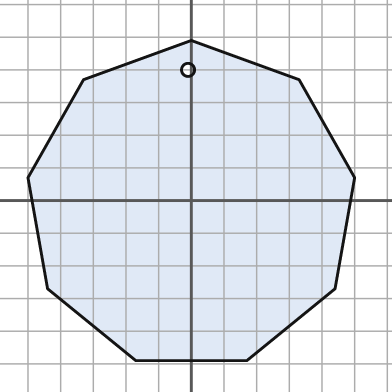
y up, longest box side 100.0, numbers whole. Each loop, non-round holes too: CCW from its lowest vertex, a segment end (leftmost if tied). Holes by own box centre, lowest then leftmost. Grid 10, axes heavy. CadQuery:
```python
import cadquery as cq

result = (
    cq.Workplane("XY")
    .moveTo(-17.0, -49.0)
    .lineTo(17.0, -49.0)
    .lineTo(44.0, -27.0)
    .lineTo(50.0, 7.0)
    .lineTo(33.0, 37.0)
    .lineTo(0.0, 49.0)
    .lineTo(-33.0, 37.0)
    .lineTo(-50.0, 7.0)
    .lineTo(-44.0, -27.0)
    .close()
    .moveTo(-1.0, 40.0)
    .circle(2.0)
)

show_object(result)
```